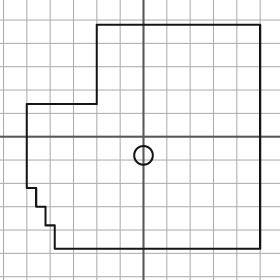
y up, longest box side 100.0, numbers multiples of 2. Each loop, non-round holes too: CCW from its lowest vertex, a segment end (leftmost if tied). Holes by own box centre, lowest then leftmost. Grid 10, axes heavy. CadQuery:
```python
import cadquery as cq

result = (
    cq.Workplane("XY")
    .moveTo(-38.0, -48.0)
    .lineTo(50.0, -48.0)
    .lineTo(50.0, 48.0)
    .lineTo(-20.0, 48.0)
    .lineTo(-20.0, 14.0)
    .lineTo(-50.0, 14.0)
    .lineTo(-50.0, -22.0)
    .lineTo(-46.0, -22.0)
    .lineTo(-46.0, -30.0)
    .lineTo(-42.0, -30.0)
    .lineTo(-42.0, -38.0)
    .lineTo(-38.0, -38.0)
    .close()
    .moveTo(0.0, -8.0)
    .circle(4.0)
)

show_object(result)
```